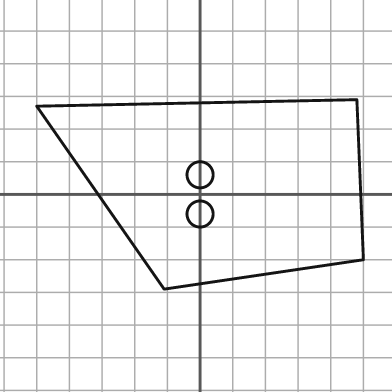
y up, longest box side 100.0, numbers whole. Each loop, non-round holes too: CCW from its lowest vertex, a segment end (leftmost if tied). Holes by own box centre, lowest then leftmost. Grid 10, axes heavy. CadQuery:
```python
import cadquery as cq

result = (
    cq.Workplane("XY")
    .moveTo(-11.0, -29.0)
    .lineTo(50.0, -20.0)
    .lineTo(48.0, 29.0)
    .lineTo(-50.0, 27.0)
    .close()
    .moveTo(0.0, -6.0)
    .circle(4.0)
    .moveTo(0.0, 6.0)
    .circle(4.0)
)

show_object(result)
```